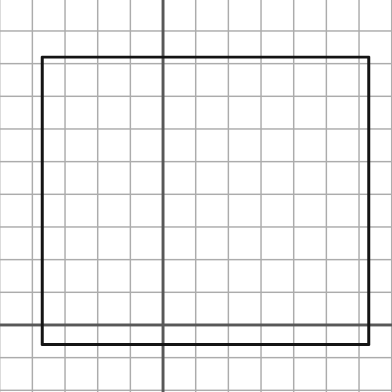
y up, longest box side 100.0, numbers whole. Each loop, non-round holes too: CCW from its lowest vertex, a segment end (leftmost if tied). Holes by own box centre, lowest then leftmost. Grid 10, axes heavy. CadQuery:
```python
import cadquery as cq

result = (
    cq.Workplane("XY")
    .moveTo(-37.0, -6.0)
    .lineTo(63.0, -6.0)
    .lineTo(63.0, 82.0)
    .lineTo(-37.0, 82.0)
    .close()
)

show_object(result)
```